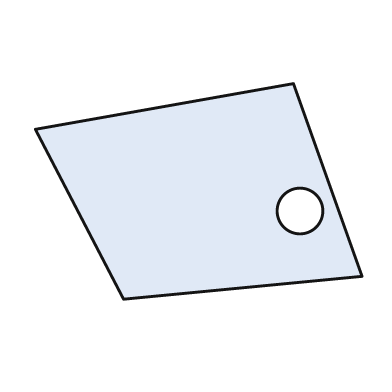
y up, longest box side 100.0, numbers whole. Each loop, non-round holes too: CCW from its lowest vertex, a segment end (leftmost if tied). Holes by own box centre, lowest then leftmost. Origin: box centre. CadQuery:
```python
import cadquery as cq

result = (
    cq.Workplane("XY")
    .moveTo(-23.0, -33.0)
    .lineTo(50.0, -26.0)
    .lineTo(29.0, 33.0)
    .lineTo(-50.0, 19.0)
    .close()
    .moveTo(31.0, -6.0)
    .circle(7.0)
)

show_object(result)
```